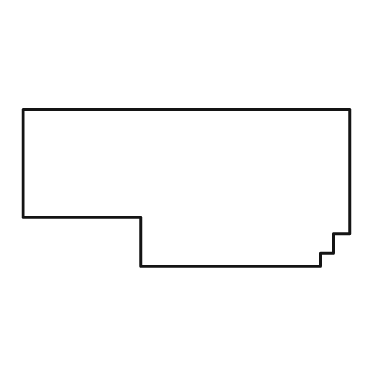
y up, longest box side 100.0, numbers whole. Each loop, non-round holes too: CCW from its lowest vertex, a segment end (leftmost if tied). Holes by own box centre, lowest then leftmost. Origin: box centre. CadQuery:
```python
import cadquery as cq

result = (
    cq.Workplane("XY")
    .moveTo(-14.0, -24.0)
    .lineTo(41.0, -24.0)
    .lineTo(41.0, -20.0)
    .lineTo(45.0, -20.0)
    .lineTo(45.0, -14.0)
    .lineTo(50.0, -14.0)
    .lineTo(50.0, 24.0)
    .lineTo(-50.0, 24.0)
    .lineTo(-50.0, -9.0)
    .lineTo(-14.0, -9.0)
    .close()
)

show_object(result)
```